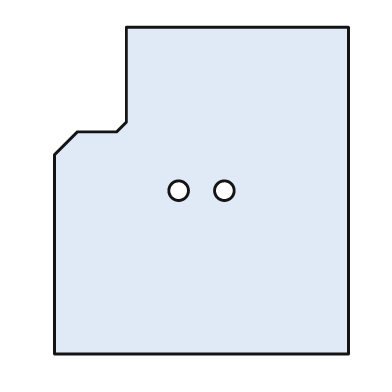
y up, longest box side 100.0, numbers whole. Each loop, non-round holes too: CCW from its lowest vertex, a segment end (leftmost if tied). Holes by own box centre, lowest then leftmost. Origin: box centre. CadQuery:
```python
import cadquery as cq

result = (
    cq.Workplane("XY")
    .moveTo(-45.0, -50.0)
    .lineTo(45.0, -50.0)
    .lineTo(45.0, 50.0)
    .lineTo(-23.0, 50.0)
    .lineTo(-23.0, 21.0)
    .lineTo(-26.0, 18.0)
    .lineTo(-38.0, 18.0)
    .lineTo(-45.0, 11.0)
    .close()
    .moveTo(-7.0, 0.0)
    .circle(3.0)
    .moveTo(7.0, 0.0)
    .circle(3.0)
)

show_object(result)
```